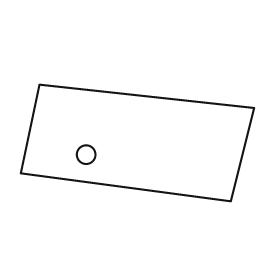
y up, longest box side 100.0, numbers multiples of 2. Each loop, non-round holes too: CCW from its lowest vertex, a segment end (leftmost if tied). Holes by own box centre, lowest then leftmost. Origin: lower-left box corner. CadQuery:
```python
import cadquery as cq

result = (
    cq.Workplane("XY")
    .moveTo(90.0, 0.0)
    .lineTo(100.0, 40.0)
    .lineTo(8.0, 50.0)
    .lineTo(0.0, 12.0)
    .close()
    .moveTo(28.0, 20.0)
    .circle(4.0)
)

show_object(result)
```